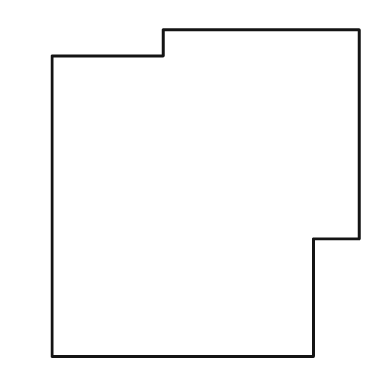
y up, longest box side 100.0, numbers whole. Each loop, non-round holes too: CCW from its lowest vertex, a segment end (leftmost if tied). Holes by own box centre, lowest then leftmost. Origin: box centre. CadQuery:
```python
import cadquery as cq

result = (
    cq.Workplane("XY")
    .moveTo(-47.0, -50.0)
    .lineTo(33.0, -50.0)
    .lineTo(33.0, -14.0)
    .lineTo(47.0, -14.0)
    .lineTo(47.0, 50.0)
    .lineTo(-13.0, 50.0)
    .lineTo(-13.0, 42.0)
    .lineTo(-47.0, 42.0)
    .close()
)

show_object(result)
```